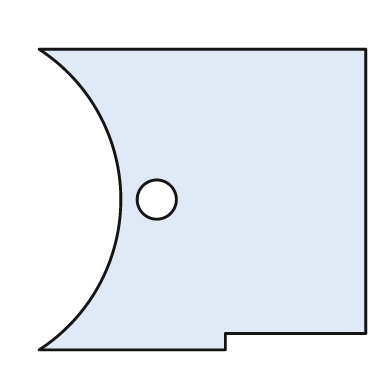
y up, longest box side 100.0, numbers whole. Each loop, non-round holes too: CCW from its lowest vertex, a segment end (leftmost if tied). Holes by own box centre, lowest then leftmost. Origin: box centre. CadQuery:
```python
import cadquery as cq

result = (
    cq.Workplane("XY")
    .moveTo(-50.0, -46.0)
    .lineTo(7.0, -46.0)
    .lineTo(7.0, -41.0)
    .lineTo(50.0, -41.0)
    .lineTo(50.0, 46.0)
    .lineTo(-50.0, 46.0)
    .threePointArc((-25.0, 0.0), (-50.0, -46.0))
    .close()
    .moveTo(-14.0, 0.0)
    .circle(6.0)
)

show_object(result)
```